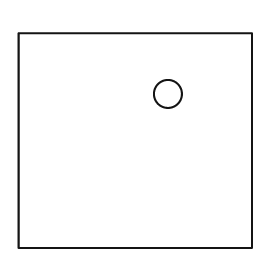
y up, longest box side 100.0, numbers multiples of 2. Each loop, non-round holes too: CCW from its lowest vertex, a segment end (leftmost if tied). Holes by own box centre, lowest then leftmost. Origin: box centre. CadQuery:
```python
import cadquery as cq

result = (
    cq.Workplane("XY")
    .moveTo(-50.0, -46.0)
    .lineTo(50.0, -46.0)
    .lineTo(50.0, 46.0)
    .lineTo(-50.0, 46.0)
    .close()
    .moveTo(14.0, 20.0)
    .circle(6.0)
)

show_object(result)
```